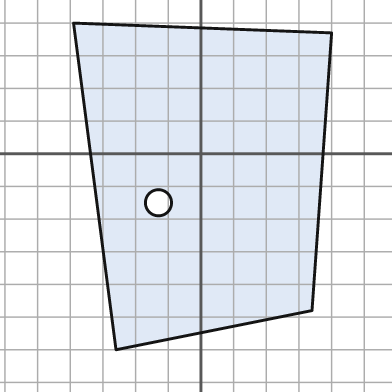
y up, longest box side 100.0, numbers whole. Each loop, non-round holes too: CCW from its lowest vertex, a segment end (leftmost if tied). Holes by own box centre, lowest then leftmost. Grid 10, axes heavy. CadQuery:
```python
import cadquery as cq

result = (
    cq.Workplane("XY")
    .moveTo(-26.0, -60.0)
    .lineTo(34.0, -48.0)
    .lineTo(40.0, 37.0)
    .lineTo(-39.0, 40.0)
    .close()
    .moveTo(-13.0, -15.0)
    .circle(4.0)
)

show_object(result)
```